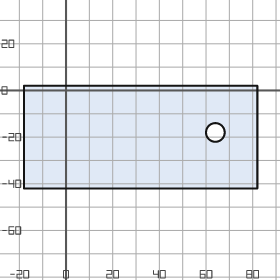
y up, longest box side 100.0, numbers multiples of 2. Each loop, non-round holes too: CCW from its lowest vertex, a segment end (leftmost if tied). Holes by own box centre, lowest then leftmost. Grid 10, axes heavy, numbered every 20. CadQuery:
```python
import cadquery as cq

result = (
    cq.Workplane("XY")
    .moveTo(-18.0, -42.0)
    .lineTo(82.0, -42.0)
    .lineTo(82.0, 2.0)
    .lineTo(-18.0, 2.0)
    .close()
    .moveTo(64.0, -18.0)
    .circle(4.0)
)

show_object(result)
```